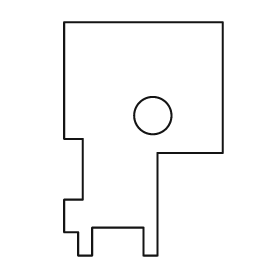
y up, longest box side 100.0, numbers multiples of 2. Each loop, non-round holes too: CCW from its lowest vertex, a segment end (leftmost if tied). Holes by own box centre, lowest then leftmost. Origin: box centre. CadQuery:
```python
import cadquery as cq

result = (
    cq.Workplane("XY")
    .moveTo(-28.0, -50.0)
    .lineTo(-22.0, -50.0)
    .lineTo(-22.0, -38.0)
    .lineTo(0.0, -38.0)
    .lineTo(0.0, -50.0)
    .lineTo(6.0, -50.0)
    .lineTo(6.0, -6.0)
    .lineTo(34.0, -6.0)
    .lineTo(34.0, 50.0)
    .lineTo(-34.0, 50.0)
    .lineTo(-34.0, 0.0)
    .lineTo(-26.0, 0.0)
    .lineTo(-26.0, -26.0)
    .lineTo(-34.0, -26.0)
    .lineTo(-34.0, -40.0)
    .lineTo(-28.0, -40.0)
    .close()
    .moveTo(4.0, 10.0)
    .circle(8.0)
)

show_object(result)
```